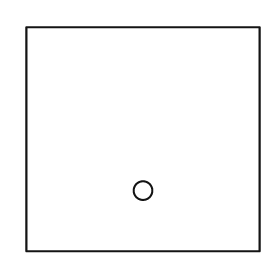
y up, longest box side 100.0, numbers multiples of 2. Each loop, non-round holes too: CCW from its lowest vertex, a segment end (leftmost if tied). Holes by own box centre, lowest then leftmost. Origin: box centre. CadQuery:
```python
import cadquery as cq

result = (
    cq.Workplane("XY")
    .moveTo(-50.0, -48.0)
    .lineTo(50.0, -48.0)
    .lineTo(50.0, 48.0)
    .lineTo(-50.0, 48.0)
    .close()
    .moveTo(0.0, -22.0)
    .circle(4.0)
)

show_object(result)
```